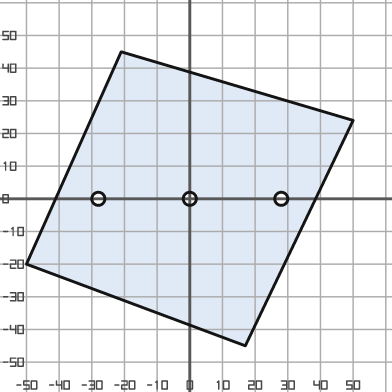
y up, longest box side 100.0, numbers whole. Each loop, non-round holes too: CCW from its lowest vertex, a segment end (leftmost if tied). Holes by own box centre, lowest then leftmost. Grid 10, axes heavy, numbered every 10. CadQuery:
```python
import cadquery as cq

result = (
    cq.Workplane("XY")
    .moveTo(17.0, -45.0)
    .lineTo(50.0, 24.0)
    .lineTo(-21.0, 45.0)
    .lineTo(-50.0, -20.0)
    .close()
    .moveTo(-28.0, 0.0)
    .circle(2.0)
    .moveTo(0.0, 0.0)
    .circle(2.0)
    .moveTo(28.0, 0.0)
    .circle(2.0)
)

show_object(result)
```